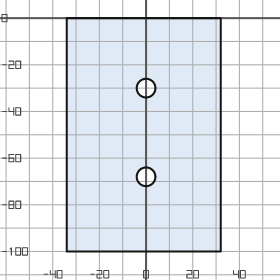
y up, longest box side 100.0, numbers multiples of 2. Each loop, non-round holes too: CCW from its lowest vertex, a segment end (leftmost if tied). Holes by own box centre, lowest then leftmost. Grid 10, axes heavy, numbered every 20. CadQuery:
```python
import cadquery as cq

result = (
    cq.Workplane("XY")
    .moveTo(-34.0, -100.0)
    .lineTo(32.0, -100.0)
    .lineTo(32.0, 0.0)
    .lineTo(-34.0, 0.0)
    .close()
    .moveTo(0.0, -68.0)
    .circle(4.0)
    .moveTo(0.0, -30.0)
    .circle(4.0)
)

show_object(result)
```